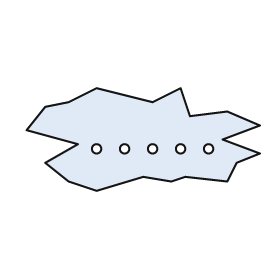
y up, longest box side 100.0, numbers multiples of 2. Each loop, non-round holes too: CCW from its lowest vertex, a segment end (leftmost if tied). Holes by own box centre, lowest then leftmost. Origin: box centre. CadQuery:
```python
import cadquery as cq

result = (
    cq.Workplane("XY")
    .moveTo(-20.0, -22.0)
    .lineTo(0.0, -16.0)
    .lineTo(12.0, -18.0)
    .lineTo(18.0, -16.0)
    .lineTo(36.0, -18.0)
    .lineTo(40.0, -10.0)
    .lineTo(50.0, -6.0)
    .lineTo(34.0, 0.0)
    .lineTo(50.0, 6.0)
    .lineTo(36.0, 12.0)
    .lineTo(20.0, 10.0)
    .lineTo(16.0, 22.0)
    .lineTo(4.0, 16.0)
    .lineTo(-20.0, 22.0)
    .lineTo(-32.0, 16.0)
    .lineTo(-42.0, 14.0)
    .lineTo(-50.0, 4.0)
    .lineTo(-28.0, -2.0)
    .lineTo(-42.0, -10.0)
    .lineTo(-32.0, -18.0)
    .close()
    .moveTo(-20.0, -4.0)
    .circle(2.0)
    .moveTo(-8.0, -4.0)
    .circle(2.0)
    .moveTo(4.0, -4.0)
    .circle(2.0)
    .moveTo(16.0, -4.0)
    .circle(2.0)
    .moveTo(28.0, -4.0)
    .circle(2.0)
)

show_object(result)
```